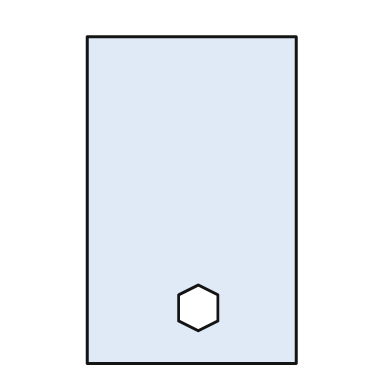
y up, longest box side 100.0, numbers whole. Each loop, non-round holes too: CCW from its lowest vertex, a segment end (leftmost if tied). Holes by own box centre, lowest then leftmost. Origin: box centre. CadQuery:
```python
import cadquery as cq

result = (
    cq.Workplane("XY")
    .moveTo(-32.0, -50.0)
    .lineTo(32.0, -50.0)
    .lineTo(32.0, 50.0)
    .lineTo(-32.0, 50.0)
    .close()
    .moveTo(2.0, -40.0)
    .lineTo(8.0, -37.0)
    .lineTo(8.0, -29.0)
    .lineTo(2.0, -26.0)
    .lineTo(-4.0, -29.0)
    .lineTo(-4.0, -37.0)
    .close()
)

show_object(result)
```